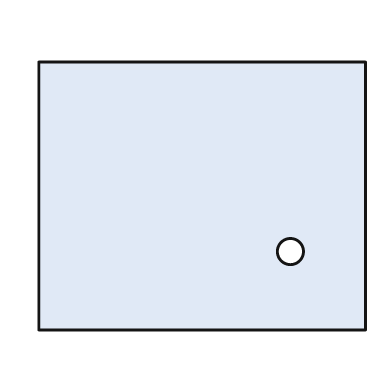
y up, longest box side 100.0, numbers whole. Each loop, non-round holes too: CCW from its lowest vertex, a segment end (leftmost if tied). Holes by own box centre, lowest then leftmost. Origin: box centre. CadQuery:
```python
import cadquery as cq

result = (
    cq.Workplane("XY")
    .moveTo(-50.0, -41.0)
    .lineTo(50.0, -41.0)
    .lineTo(50.0, 41.0)
    .lineTo(-50.0, 41.0)
    .close()
    .moveTo(27.0, -17.0)
    .circle(4.0)
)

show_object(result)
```